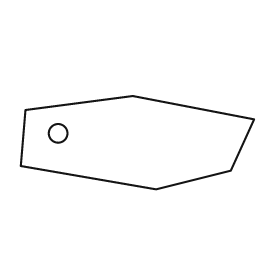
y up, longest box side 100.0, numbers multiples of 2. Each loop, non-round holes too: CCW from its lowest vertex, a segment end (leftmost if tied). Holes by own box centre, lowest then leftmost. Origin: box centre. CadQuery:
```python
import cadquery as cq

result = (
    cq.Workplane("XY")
    .moveTo(8.0, -20.0)
    .lineTo(40.0, -12.0)
    .lineTo(50.0, 10.0)
    .lineTo(-2.0, 20.0)
    .lineTo(-48.0, 14.0)
    .lineTo(-50.0, -10.0)
    .close()
    .moveTo(-34.0, 4.0)
    .circle(4.0)
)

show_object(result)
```